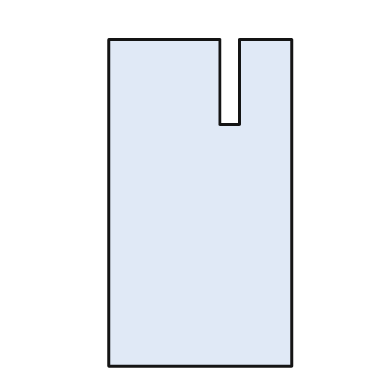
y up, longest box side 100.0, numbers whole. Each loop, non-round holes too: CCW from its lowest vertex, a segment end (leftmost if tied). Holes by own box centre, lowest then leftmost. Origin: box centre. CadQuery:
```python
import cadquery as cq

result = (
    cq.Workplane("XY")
    .moveTo(-28.0, -50.0)
    .lineTo(28.0, -50.0)
    .lineTo(28.0, 50.0)
    .lineTo(12.0, 50.0)
    .lineTo(12.0, 24.0)
    .lineTo(6.0, 24.0)
    .lineTo(6.0, 50.0)
    .lineTo(-28.0, 50.0)
    .close()
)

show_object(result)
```